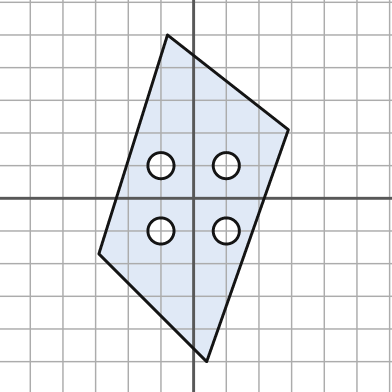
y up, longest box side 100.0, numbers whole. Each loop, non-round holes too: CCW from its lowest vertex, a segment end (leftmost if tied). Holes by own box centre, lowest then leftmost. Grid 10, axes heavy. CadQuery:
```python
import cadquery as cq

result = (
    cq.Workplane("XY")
    .moveTo(4.0, -50.0)
    .lineTo(29.0, 21.0)
    .lineTo(-8.0, 50.0)
    .lineTo(-29.0, -17.0)
    .close()
    .moveTo(-10.0, -10.0)
    .circle(4.0)
    .moveTo(10.0, -10.0)
    .circle(4.0)
    .moveTo(-10.0, 10.0)
    .circle(4.0)
    .moveTo(10.0, 10.0)
    .circle(4.0)
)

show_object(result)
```